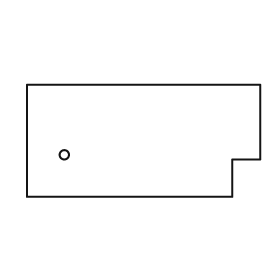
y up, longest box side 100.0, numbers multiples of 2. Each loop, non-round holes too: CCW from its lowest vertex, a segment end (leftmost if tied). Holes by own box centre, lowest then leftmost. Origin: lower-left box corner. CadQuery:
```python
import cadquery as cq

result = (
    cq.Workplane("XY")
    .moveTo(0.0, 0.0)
    .lineTo(88.0, 0.0)
    .lineTo(88.0, 16.0)
    .lineTo(100.0, 16.0)
    .lineTo(100.0, 48.0)
    .lineTo(0.0, 48.0)
    .close()
    .moveTo(16.0, 18.0)
    .circle(2.0)
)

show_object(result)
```